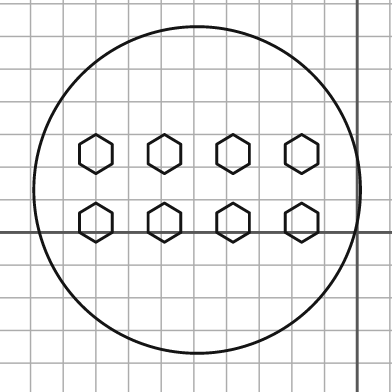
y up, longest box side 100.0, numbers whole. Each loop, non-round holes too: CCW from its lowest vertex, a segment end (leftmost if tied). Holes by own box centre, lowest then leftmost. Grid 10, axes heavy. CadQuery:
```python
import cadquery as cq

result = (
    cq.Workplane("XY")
    .moveTo(-49.0, 13.0)
    .circle(50.0)
    .moveTo(-80.0, -3.0)
    .lineTo(-75.0, 0.0)
    .lineTo(-75.0, 6.0)
    .lineTo(-80.0, 9.0)
    .lineTo(-85.0, 6.0)
    .lineTo(-85.0, 0.0)
    .close()
    .moveTo(-59.0, -3.0)
    .lineTo(-54.0, 0.0)
    .lineTo(-54.0, 6.0)
    .lineTo(-59.0, 9.0)
    .lineTo(-64.0, 6.0)
    .lineTo(-64.0, 0.0)
    .close()
    .moveTo(-38.0, -3.0)
    .lineTo(-33.0, 0.0)
    .lineTo(-33.0, 6.0)
    .lineTo(-38.0, 9.0)
    .lineTo(-43.0, 6.0)
    .lineTo(-43.0, 0.0)
    .close()
    .moveTo(-17.0, -3.0)
    .lineTo(-12.0, 0.0)
    .lineTo(-12.0, 6.0)
    .lineTo(-17.0, 9.0)
    .lineTo(-22.0, 6.0)
    .lineTo(-22.0, 0.0)
    .close()
    .moveTo(-80.0, 18.0)
    .lineTo(-75.0, 21.0)
    .lineTo(-75.0, 27.0)
    .lineTo(-80.0, 30.0)
    .lineTo(-85.0, 27.0)
    .lineTo(-85.0, 21.0)
    .close()
    .moveTo(-59.0, 18.0)
    .lineTo(-54.0, 21.0)
    .lineTo(-54.0, 27.0)
    .lineTo(-59.0, 30.0)
    .lineTo(-64.0, 27.0)
    .lineTo(-64.0, 21.0)
    .close()
    .moveTo(-38.0, 18.0)
    .lineTo(-33.0, 21.0)
    .lineTo(-33.0, 27.0)
    .lineTo(-38.0, 30.0)
    .lineTo(-43.0, 27.0)
    .lineTo(-43.0, 21.0)
    .close()
    .moveTo(-17.0, 18.0)
    .lineTo(-12.0, 21.0)
    .lineTo(-12.0, 27.0)
    .lineTo(-17.0, 30.0)
    .lineTo(-22.0, 27.0)
    .lineTo(-22.0, 21.0)
    .close()
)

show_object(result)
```